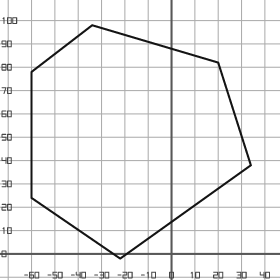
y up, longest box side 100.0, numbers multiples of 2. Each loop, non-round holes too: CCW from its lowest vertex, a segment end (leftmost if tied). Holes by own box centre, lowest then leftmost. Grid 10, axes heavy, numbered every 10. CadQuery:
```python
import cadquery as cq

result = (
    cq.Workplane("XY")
    .moveTo(-22.0, -2.0)
    .lineTo(34.0, 38.0)
    .lineTo(20.0, 82.0)
    .lineTo(-34.0, 98.0)
    .lineTo(-60.0, 78.0)
    .lineTo(-60.0, 24.0)
    .close()
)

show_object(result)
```